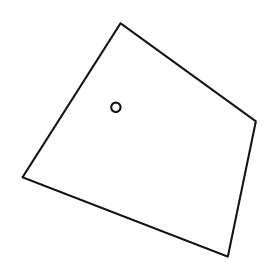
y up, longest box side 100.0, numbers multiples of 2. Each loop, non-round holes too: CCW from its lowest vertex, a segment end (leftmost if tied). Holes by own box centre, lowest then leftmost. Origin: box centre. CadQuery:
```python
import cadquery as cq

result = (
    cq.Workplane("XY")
    .moveTo(38.0, -50.0)
    .lineTo(50.0, 8.0)
    .lineTo(-8.0, 50.0)
    .lineTo(-50.0, -16.0)
    .close()
    .moveTo(-10.0, 14.0)
    .circle(2.0)
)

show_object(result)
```